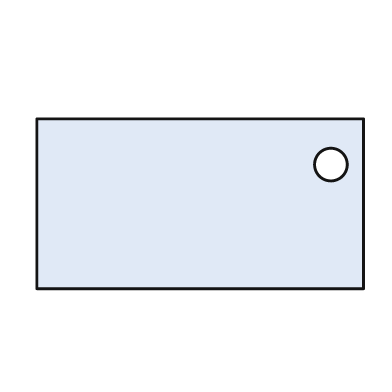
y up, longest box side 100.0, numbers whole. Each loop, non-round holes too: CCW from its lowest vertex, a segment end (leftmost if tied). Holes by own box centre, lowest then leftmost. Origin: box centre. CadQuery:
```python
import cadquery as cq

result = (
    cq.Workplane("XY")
    .moveTo(-50.0, -26.0)
    .lineTo(50.0, -26.0)
    .lineTo(50.0, 26.0)
    .lineTo(-50.0, 26.0)
    .close()
    .moveTo(40.0, 12.0)
    .circle(5.0)
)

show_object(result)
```